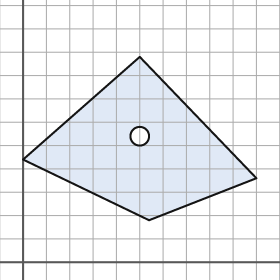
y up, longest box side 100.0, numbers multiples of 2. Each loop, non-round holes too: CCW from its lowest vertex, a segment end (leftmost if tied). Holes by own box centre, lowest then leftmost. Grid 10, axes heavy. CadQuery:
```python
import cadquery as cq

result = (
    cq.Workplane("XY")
    .moveTo(54.0, 18.0)
    .lineTo(100.0, 36.0)
    .lineTo(50.0, 88.0)
    .lineTo(0.0, 44.0)
    .close()
    .moveTo(50.0, 54.0)
    .circle(4.0)
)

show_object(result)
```